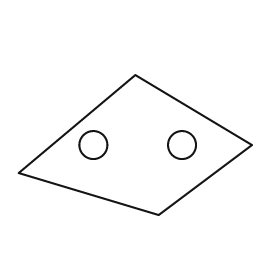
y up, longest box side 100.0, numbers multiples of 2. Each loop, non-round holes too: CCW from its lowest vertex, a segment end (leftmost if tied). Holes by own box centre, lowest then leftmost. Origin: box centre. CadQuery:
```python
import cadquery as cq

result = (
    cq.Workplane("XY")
    .moveTo(10.0, -30.0)
    .lineTo(50.0, 0.0)
    .lineTo(0.0, 30.0)
    .lineTo(-50.0, -12.0)
    .close()
    .moveTo(-18.0, 0.0)
    .circle(6.0)
    .moveTo(20.0, 0.0)
    .circle(6.0)
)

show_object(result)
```